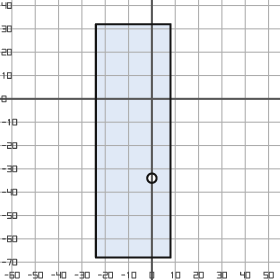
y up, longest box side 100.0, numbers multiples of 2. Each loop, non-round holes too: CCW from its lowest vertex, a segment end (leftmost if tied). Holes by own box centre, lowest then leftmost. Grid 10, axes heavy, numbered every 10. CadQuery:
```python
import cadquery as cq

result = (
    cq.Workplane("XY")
    .moveTo(-24.0, -68.0)
    .lineTo(8.0, -68.0)
    .lineTo(8.0, 32.0)
    .lineTo(-24.0, 32.0)
    .close()
    .moveTo(0.0, -34.0)
    .circle(2.0)
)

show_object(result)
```